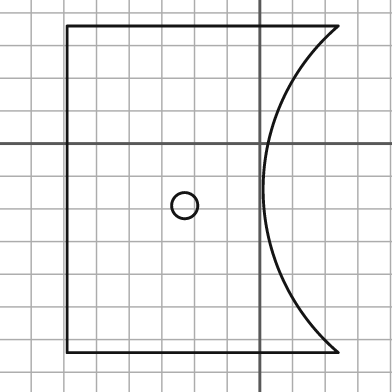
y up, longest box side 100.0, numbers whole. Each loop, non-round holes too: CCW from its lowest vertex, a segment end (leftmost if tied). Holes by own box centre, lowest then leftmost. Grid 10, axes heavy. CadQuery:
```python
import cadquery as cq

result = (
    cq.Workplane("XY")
    .moveTo(-59.0, -64.0)
    .lineTo(24.0, -64.0)
    .threePointArc((1.0, -14.0), (24.0, 36.0))
    .lineTo(-59.0, 36.0)
    .close()
    .moveTo(-23.0, -19.0)
    .circle(4.0)
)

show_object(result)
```